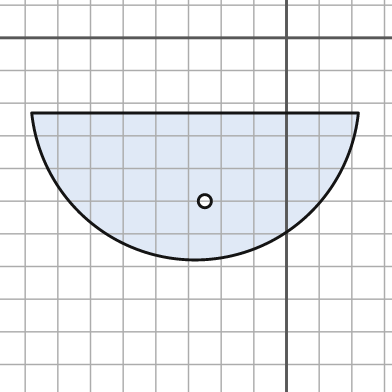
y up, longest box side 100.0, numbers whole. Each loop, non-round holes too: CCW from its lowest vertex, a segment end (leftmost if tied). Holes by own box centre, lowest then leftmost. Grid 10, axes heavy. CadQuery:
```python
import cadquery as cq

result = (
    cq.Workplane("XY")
    .moveTo(-78.0, -23.0)
    .threePointArc((-28.0, -68.0), (22.0, -23.0))
    .close()
    .moveTo(-25.0, -50.0)
    .circle(2.0)
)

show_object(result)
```